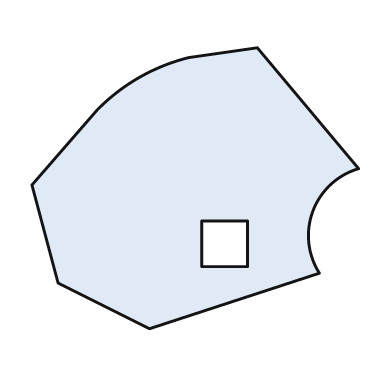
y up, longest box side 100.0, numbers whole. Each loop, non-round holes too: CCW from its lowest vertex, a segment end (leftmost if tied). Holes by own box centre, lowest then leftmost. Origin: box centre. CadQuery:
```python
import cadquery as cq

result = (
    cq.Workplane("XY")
    .moveTo(-14.0, -43.0)
    .lineTo(38.0, -26.0)
    .threePointArc((36.0, -7.0), (50.0, 6.0))
    .lineTo(19.0, 43.0)
    .lineTo(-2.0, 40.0)
    .threePointArc((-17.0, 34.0), (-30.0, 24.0))
    .lineTo(-50.0, 1.0)
    .lineTo(-42.0, -29.0)
    .close()
    .moveTo(2.0, -24.0)
    .lineTo(16.0, -24.0)
    .lineTo(16.0, -10.0)
    .lineTo(2.0, -10.0)
    .close()
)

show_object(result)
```